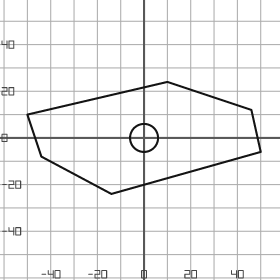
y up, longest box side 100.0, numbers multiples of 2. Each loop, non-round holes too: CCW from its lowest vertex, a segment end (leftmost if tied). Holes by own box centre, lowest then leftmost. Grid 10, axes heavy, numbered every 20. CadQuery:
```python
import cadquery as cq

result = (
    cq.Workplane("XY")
    .moveTo(-14.0, -24.0)
    .lineTo(50.0, -6.0)
    .lineTo(46.0, 12.0)
    .lineTo(10.0, 24.0)
    .lineTo(-50.0, 10.0)
    .lineTo(-44.0, -8.0)
    .close()
    .moveTo(0.0, 0.0)
    .circle(6.0)
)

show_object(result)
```